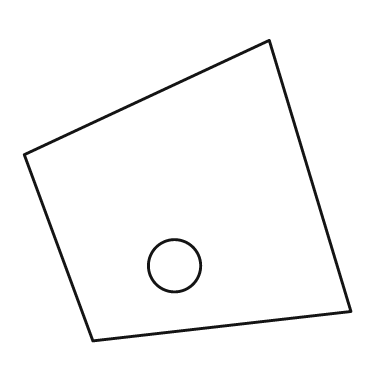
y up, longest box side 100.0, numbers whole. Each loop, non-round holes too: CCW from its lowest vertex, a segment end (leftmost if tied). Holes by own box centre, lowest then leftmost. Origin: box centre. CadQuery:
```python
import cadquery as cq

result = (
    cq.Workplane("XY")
    .moveTo(-29.0, -46.0)
    .lineTo(50.0, -37.0)
    .lineTo(25.0, 46.0)
    .lineTo(-50.0, 11.0)
    .close()
    .moveTo(-4.0, -23.0)
    .circle(8.0)
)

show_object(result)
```